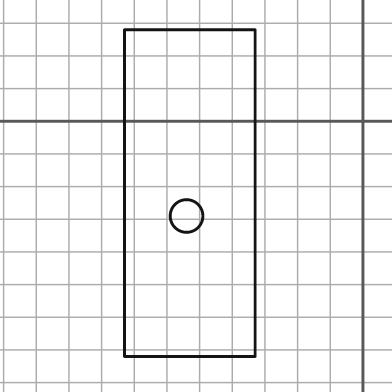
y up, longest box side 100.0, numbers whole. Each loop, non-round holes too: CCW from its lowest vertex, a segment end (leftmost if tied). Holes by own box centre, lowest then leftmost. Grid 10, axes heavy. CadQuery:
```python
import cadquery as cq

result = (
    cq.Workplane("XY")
    .moveTo(-73.0, -72.0)
    .lineTo(-33.0, -72.0)
    .lineTo(-33.0, 28.0)
    .lineTo(-73.0, 28.0)
    .close()
    .moveTo(-54.0, -29.0)
    .circle(5.0)
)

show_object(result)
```